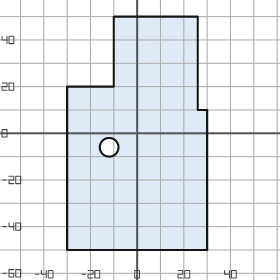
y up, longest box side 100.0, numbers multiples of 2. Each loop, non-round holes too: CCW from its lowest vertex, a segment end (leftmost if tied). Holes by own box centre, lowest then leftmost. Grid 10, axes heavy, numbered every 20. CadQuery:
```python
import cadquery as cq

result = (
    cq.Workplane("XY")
    .moveTo(-30.0, -50.0)
    .lineTo(30.0, -50.0)
    .lineTo(30.0, 10.0)
    .lineTo(26.0, 10.0)
    .lineTo(26.0, 50.0)
    .lineTo(-10.0, 50.0)
    .lineTo(-10.0, 20.0)
    .lineTo(-30.0, 20.0)
    .close()
    .moveTo(-12.0, -6.0)
    .circle(4.0)
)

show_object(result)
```